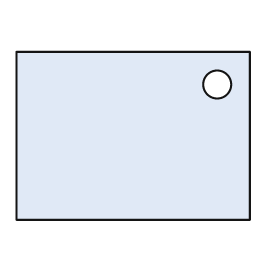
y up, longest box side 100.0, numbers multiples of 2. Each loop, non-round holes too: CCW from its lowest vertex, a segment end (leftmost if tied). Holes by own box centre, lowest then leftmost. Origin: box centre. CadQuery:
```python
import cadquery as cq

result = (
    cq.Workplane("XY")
    .moveTo(-50.0, -36.0)
    .lineTo(50.0, -36.0)
    .lineTo(50.0, 36.0)
    .lineTo(-50.0, 36.0)
    .close()
    .moveTo(36.0, 22.0)
    .circle(6.0)
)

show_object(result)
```